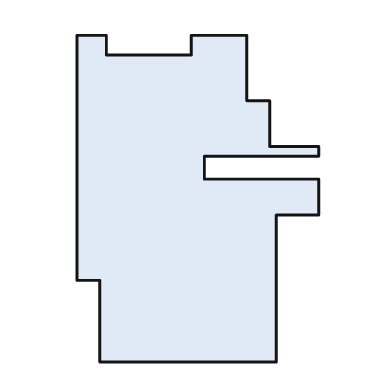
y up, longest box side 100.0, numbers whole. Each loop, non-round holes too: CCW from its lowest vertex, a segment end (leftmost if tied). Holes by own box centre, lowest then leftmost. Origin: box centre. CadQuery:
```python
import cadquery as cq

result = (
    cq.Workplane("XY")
    .moveTo(-30.0, -50.0)
    .lineTo(24.0, -50.0)
    .lineTo(24.0, -5.0)
    .lineTo(37.0, -5.0)
    .lineTo(37.0, 6.0)
    .lineTo(2.0, 6.0)
    .lineTo(2.0, 13.0)
    .lineTo(37.0, 13.0)
    .lineTo(37.0, 16.0)
    .lineTo(22.0, 16.0)
    .lineTo(22.0, 30.0)
    .lineTo(15.0, 30.0)
    .lineTo(15.0, 50.0)
    .lineTo(-2.0, 50.0)
    .lineTo(-2.0, 44.0)
    .lineTo(-28.0, 44.0)
    .lineTo(-28.0, 50.0)
    .lineTo(-37.0, 50.0)
    .lineTo(-37.0, -25.0)
    .lineTo(-30.0, -25.0)
    .close()
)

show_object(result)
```